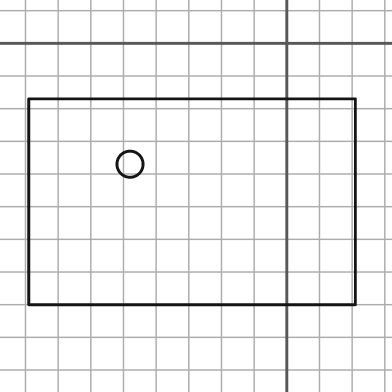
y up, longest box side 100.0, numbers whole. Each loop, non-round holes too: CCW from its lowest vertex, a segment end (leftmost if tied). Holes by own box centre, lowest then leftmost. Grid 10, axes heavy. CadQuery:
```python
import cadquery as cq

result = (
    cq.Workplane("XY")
    .moveTo(-79.0, -80.0)
    .lineTo(21.0, -80.0)
    .lineTo(21.0, -17.0)
    .lineTo(-79.0, -17.0)
    .close()
    .moveTo(-48.0, -37.0)
    .circle(4.0)
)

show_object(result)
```